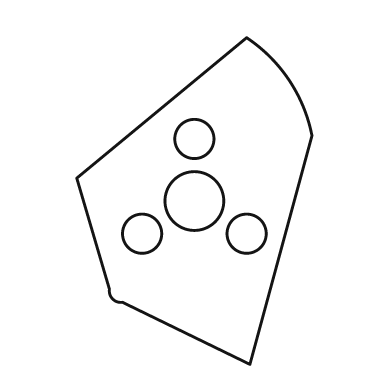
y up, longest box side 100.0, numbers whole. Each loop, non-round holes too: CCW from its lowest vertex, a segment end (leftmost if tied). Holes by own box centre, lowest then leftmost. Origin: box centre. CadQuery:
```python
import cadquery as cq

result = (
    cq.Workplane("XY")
    .moveTo(17.0, -50.0)
    .lineTo(36.0, 20.0)
    .threePointArc((29.0, 37.0), (16.0, 50.0))
    .lineTo(-36.0, 7.0)
    .lineTo(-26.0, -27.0)
    .threePointArc((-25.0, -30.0), (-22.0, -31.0))
    .close()
    .moveTo(-16.0, -10.0)
    .circle(6.0)
    .moveTo(16.0, -10.0)
    .circle(6.0)
    .moveTo(0.0, 0.0)
    .circle(9.0)
    .moveTo(0.0, 19.0)
    .circle(6.0)
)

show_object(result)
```